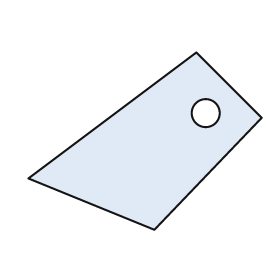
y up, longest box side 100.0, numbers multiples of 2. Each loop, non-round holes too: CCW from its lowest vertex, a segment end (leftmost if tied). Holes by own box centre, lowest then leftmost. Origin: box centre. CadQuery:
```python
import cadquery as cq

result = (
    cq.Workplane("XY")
    .moveTo(4.0, -38.0)
    .lineTo(50.0, 10.0)
    .lineTo(22.0, 38.0)
    .lineTo(-50.0, -16.0)
    .close()
    .moveTo(26.0, 12.0)
    .circle(6.0)
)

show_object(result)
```